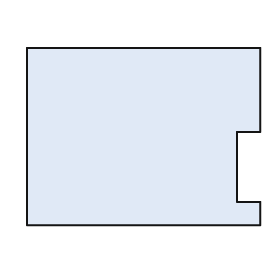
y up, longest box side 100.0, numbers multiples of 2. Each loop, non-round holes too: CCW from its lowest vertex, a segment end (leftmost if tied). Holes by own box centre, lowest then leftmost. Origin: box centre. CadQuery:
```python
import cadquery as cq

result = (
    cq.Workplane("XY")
    .moveTo(-50.0, -38.0)
    .lineTo(50.0, -38.0)
    .lineTo(50.0, -28.0)
    .lineTo(40.0, -28.0)
    .lineTo(40.0, 2.0)
    .lineTo(50.0, 2.0)
    .lineTo(50.0, 38.0)
    .lineTo(-50.0, 38.0)
    .close()
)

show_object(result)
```